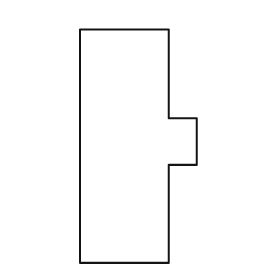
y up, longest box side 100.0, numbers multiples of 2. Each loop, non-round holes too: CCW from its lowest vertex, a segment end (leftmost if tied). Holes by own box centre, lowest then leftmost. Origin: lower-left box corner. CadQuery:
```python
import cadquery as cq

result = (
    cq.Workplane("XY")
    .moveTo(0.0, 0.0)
    .lineTo(38.0, 0.0)
    .lineTo(38.0, 42.0)
    .lineTo(50.0, 42.0)
    .lineTo(50.0, 62.0)
    .lineTo(38.0, 62.0)
    .lineTo(38.0, 100.0)
    .lineTo(0.0, 100.0)
    .close()
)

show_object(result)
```